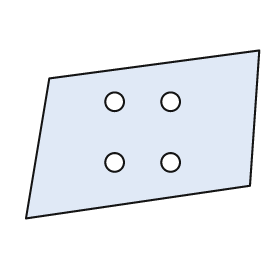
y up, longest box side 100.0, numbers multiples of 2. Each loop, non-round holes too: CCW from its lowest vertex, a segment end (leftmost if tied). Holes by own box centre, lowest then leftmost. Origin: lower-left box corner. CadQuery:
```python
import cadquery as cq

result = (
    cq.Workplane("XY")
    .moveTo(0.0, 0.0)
    .lineTo(96.0, 14.0)
    .lineTo(100.0, 72.0)
    .lineTo(10.0, 60.0)
    .close()
    .moveTo(38.0, 24.0)
    .circle(4.0)
    .moveTo(62.0, 24.0)
    .circle(4.0)
    .moveTo(38.0, 50.0)
    .circle(4.0)
    .moveTo(62.0, 50.0)
    .circle(4.0)
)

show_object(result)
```